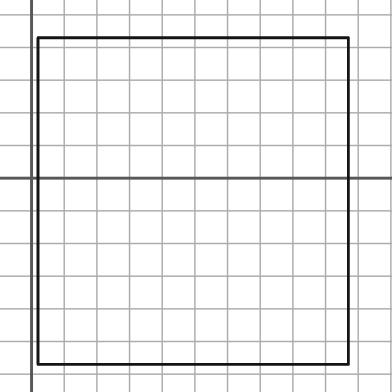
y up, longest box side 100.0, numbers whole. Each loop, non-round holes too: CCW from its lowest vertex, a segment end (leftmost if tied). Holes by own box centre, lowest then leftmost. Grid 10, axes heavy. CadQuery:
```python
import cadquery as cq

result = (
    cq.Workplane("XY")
    .moveTo(2.0, -57.0)
    .lineTo(97.0, -57.0)
    .lineTo(97.0, 43.0)
    .lineTo(2.0, 43.0)
    .close()
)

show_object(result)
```